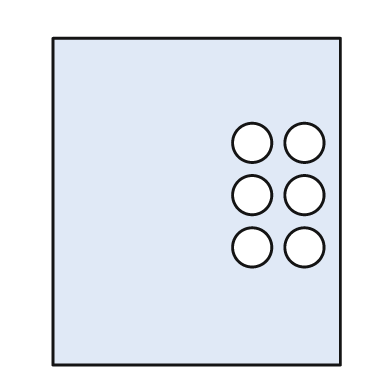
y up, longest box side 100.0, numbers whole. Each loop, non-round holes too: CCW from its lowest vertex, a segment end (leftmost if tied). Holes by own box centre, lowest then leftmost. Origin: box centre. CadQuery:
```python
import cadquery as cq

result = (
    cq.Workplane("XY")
    .moveTo(-44.0, -50.0)
    .lineTo(44.0, -50.0)
    .lineTo(44.0, 50.0)
    .lineTo(-44.0, 50.0)
    .close()
    .moveTo(17.0, -14.0)
    .circle(6.0)
    .moveTo(33.0, -14.0)
    .circle(6.0)
    .moveTo(17.0, 2.0)
    .circle(6.0)
    .moveTo(33.0, 2.0)
    .circle(6.0)
    .moveTo(17.0, 18.0)
    .circle(6.0)
    .moveTo(33.0, 18.0)
    .circle(6.0)
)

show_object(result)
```